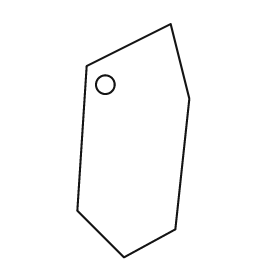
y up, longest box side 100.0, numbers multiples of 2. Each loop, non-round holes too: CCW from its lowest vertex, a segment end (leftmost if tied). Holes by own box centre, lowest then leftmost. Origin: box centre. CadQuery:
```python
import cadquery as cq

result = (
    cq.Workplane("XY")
    .moveTo(-4.0, -50.0)
    .lineTo(18.0, -38.0)
    .lineTo(24.0, 18.0)
    .lineTo(16.0, 50.0)
    .lineTo(-20.0, 32.0)
    .lineTo(-24.0, -30.0)
    .close()
    .moveTo(-12.0, 24.0)
    .circle(4.0)
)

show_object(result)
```